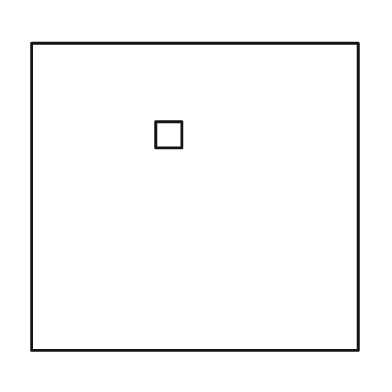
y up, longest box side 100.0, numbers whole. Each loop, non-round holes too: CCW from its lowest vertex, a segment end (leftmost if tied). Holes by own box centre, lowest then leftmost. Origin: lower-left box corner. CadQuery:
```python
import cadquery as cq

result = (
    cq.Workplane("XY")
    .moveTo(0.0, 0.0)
    .lineTo(100.0, 0.0)
    .lineTo(100.0, 94.0)
    .lineTo(0.0, 94.0)
    .close()
    .moveTo(38.0, 62.0)
    .lineTo(46.0, 62.0)
    .lineTo(46.0, 70.0)
    .lineTo(38.0, 70.0)
    .close()
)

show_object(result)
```